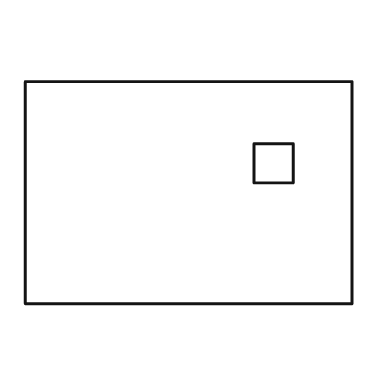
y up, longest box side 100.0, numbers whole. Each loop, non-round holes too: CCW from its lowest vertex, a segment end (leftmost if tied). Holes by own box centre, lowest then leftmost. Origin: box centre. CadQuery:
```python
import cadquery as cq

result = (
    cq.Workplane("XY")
    .moveTo(-50.0, -34.0)
    .lineTo(50.0, -34.0)
    .lineTo(50.0, 34.0)
    .lineTo(-50.0, 34.0)
    .close()
    .moveTo(20.0, 3.0)
    .lineTo(32.0, 3.0)
    .lineTo(32.0, 15.0)
    .lineTo(20.0, 15.0)
    .close()
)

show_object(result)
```